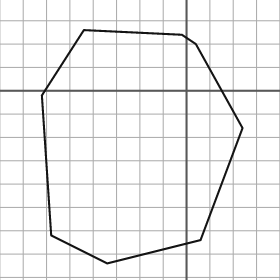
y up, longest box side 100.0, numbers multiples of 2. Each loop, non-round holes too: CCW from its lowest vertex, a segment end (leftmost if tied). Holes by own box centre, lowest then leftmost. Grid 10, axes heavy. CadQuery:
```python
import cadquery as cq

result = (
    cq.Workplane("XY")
    .moveTo(-34.0, -74.0)
    .lineTo(6.0, -64.0)
    .lineTo(24.0, -16.0)
    .lineTo(4.0, 20.0)
    .lineTo(-2.0, 24.0)
    .lineTo(-44.0, 26.0)
    .lineTo(-62.0, -2.0)
    .lineTo(-58.0, -62.0)
    .close()
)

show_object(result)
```